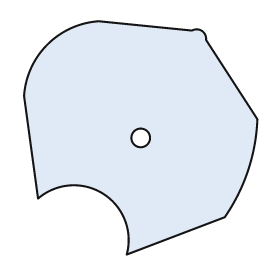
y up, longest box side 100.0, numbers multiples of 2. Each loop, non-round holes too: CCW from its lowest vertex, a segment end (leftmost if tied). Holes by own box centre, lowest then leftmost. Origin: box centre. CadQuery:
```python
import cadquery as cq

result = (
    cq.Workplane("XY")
    .moveTo(-6.0, -50.0)
    .lineTo(36.0, -34.0)
    .threePointArc((46.0, -14.0), (50.0, 8.0))
    .lineTo(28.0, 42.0)
    .threePointArc((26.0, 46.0), (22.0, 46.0))
    .lineTo(-18.0, 50.0)
    .threePointArc((-40.0, 40.0), (-50.0, 18.0))
    .lineTo(-44.0, -26.0)
    .threePointArc((-16.0, -24.0), (-6.0, -50.0))
    .close()
    .moveTo(0.0, 0.0)
    .circle(4.0)
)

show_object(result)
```